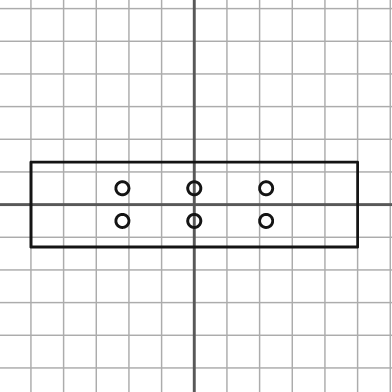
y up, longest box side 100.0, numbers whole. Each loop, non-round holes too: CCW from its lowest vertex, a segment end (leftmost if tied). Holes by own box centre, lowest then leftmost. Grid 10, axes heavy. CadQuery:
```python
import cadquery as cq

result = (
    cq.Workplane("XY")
    .moveTo(-50.0, -13.0)
    .lineTo(50.0, -13.0)
    .lineTo(50.0, 13.0)
    .lineTo(-50.0, 13.0)
    .close()
    .moveTo(-22.0, -5.0)
    .circle(2.0)
    .moveTo(0.0, -5.0)
    .circle(2.0)
    .moveTo(22.0, -5.0)
    .circle(2.0)
    .moveTo(-22.0, 5.0)
    .circle(2.0)
    .moveTo(0.0, 5.0)
    .circle(2.0)
    .moveTo(22.0, 5.0)
    .circle(2.0)
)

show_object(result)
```